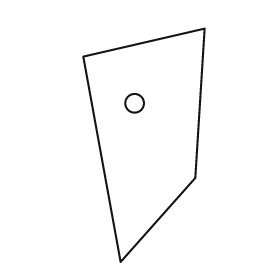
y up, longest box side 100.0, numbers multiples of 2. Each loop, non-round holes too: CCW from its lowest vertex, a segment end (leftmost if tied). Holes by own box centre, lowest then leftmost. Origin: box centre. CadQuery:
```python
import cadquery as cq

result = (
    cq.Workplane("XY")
    .moveTo(-10.0, -50.0)
    .lineTo(22.0, -14.0)
    .lineTo(26.0, 50.0)
    .lineTo(-26.0, 38.0)
    .close()
    .moveTo(-4.0, 18.0)
    .circle(4.0)
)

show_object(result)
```